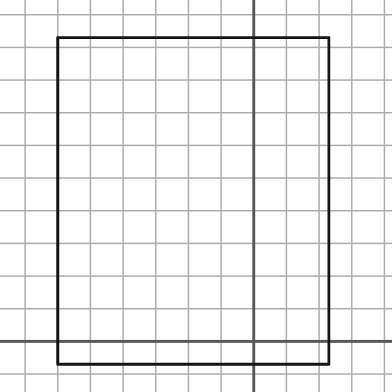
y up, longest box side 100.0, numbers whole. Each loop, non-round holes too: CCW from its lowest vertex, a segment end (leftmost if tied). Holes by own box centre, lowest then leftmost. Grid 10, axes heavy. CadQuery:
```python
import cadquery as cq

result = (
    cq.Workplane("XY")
    .moveTo(-60.0, -7.0)
    .lineTo(23.0, -7.0)
    .lineTo(23.0, 93.0)
    .lineTo(-60.0, 93.0)
    .close()
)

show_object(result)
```